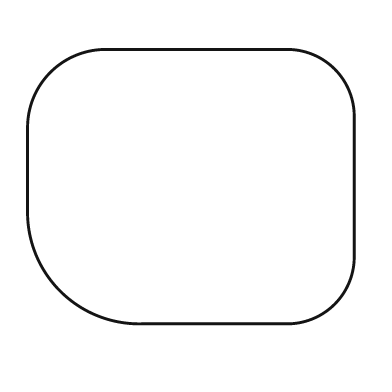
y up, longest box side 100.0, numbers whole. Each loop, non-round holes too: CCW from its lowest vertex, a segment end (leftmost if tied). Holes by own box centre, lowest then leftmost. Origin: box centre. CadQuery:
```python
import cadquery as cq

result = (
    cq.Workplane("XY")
    .moveTo(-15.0, -42.0)
    .lineTo(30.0, -42.0)
    .threePointArc((44.0, -36.0), (50.0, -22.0))
    .lineTo(50.0, 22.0)
    .threePointArc((44.0, 36.0), (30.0, 42.0))
    .lineTo(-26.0, 42.0)
    .threePointArc((-43.0, 35.0), (-50.0, 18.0))
    .lineTo(-50.0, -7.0)
    .threePointArc((-40.0, -32.0), (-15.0, -42.0))
    .close()
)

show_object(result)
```